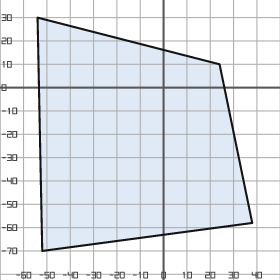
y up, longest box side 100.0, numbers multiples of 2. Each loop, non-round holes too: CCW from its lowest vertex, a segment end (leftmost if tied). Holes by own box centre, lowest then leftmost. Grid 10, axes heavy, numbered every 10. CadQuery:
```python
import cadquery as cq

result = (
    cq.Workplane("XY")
    .moveTo(-52.0, -70.0)
    .lineTo(38.0, -58.0)
    .lineTo(24.0, 10.0)
    .lineTo(-54.0, 30.0)
    .close()
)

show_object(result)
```